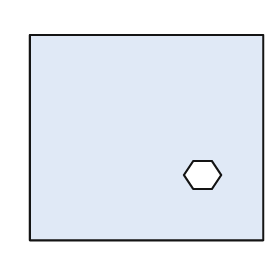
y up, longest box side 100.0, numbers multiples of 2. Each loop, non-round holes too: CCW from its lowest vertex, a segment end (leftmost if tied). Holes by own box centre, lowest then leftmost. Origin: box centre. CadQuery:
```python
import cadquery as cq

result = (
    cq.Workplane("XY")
    .moveTo(-50.0, -44.0)
    .lineTo(50.0, -44.0)
    .lineTo(50.0, 44.0)
    .lineTo(-50.0, 44.0)
    .close()
    .moveTo(20.0, -22.0)
    .lineTo(28.0, -22.0)
    .lineTo(32.0, -16.0)
    .lineTo(28.0, -10.0)
    .lineTo(20.0, -10.0)
    .lineTo(16.0, -16.0)
    .close()
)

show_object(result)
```